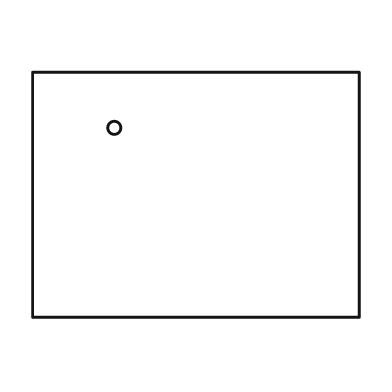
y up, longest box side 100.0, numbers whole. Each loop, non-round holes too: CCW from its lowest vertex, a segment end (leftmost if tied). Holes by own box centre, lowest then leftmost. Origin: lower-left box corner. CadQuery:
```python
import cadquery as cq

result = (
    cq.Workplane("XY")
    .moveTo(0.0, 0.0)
    .lineTo(100.0, 0.0)
    .lineTo(100.0, 75.0)
    .lineTo(0.0, 75.0)
    .close()
    .moveTo(25.0, 58.0)
    .circle(2.0)
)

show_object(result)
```